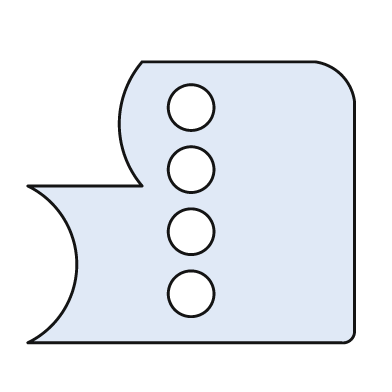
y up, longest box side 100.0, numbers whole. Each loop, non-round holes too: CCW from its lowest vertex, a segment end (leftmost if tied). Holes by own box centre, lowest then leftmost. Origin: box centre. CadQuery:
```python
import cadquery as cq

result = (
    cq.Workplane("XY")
    .moveTo(-50.0, -43.0)
    .lineTo(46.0, -43.0)
    .threePointArc((49.0, -42.0), (50.0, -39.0))
    .lineTo(50.0, 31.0)
    .threePointArc((46.0, 39.0), (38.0, 43.0))
    .lineTo(-15.0, 43.0)
    .threePointArc((-22.0, 24.0), (-15.0, 5.0))
    .lineTo(-50.0, 5.0)
    .threePointArc((-35.0, -19.0), (-50.0, -43.0))
    .close()
    .moveTo(0.0, -28.0)
    .circle(7.0)
    .moveTo(0.0, -9.0)
    .circle(7.0)
    .moveTo(0.0, 10.0)
    .circle(7.0)
    .moveTo(0.0, 29.0)
    .circle(7.0)
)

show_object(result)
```